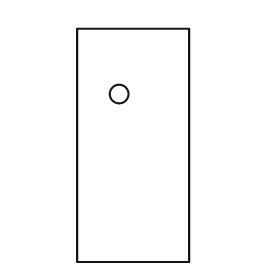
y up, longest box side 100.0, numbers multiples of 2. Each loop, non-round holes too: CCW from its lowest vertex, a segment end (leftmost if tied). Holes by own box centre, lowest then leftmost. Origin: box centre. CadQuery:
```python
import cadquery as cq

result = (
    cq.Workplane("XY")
    .moveTo(-24.0, -50.0)
    .lineTo(24.0, -50.0)
    .lineTo(24.0, 50.0)
    .lineTo(-24.0, 50.0)
    .close()
    .moveTo(-6.0, 22.0)
    .circle(4.0)
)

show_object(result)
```